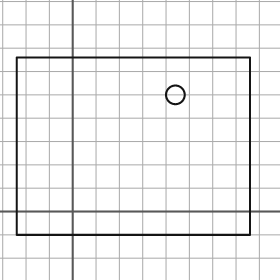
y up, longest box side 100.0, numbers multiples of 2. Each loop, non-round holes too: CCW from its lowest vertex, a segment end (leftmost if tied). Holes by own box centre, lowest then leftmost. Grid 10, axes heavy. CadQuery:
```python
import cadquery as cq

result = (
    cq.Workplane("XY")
    .moveTo(-24.0, -10.0)
    .lineTo(76.0, -10.0)
    .lineTo(76.0, 66.0)
    .lineTo(-24.0, 66.0)
    .close()
    .moveTo(44.0, 50.0)
    .circle(4.0)
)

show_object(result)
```